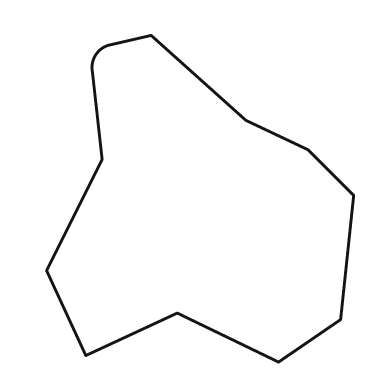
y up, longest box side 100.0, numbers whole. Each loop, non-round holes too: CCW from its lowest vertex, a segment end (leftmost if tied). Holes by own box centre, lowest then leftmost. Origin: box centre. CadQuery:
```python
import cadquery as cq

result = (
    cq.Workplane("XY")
    .moveTo(24.0, -50.0)
    .lineTo(43.0, -37.0)
    .lineTo(47.0, 1.0)
    .lineTo(33.0, 15.0)
    .lineTo(14.0, 24.0)
    .lineTo(-15.0, 50.0)
    .lineTo(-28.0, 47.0)
    .threePointArc((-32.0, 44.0), (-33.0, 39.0))
    .lineTo(-30.0, 12.0)
    .lineTo(-47.0, -22.0)
    .lineTo(-35.0, -48.0)
    .lineTo(-7.0, -35.0)
    .close()
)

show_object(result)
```